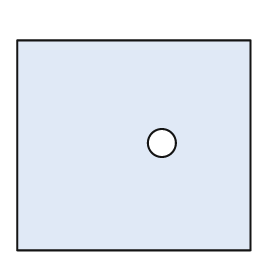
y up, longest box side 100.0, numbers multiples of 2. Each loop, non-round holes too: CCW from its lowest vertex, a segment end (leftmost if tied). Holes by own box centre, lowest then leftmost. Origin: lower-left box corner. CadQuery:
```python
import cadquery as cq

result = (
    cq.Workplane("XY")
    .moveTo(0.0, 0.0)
    .lineTo(100.0, 0.0)
    .lineTo(100.0, 90.0)
    .lineTo(0.0, 90.0)
    .close()
    .moveTo(62.0, 46.0)
    .circle(6.0)
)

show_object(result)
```